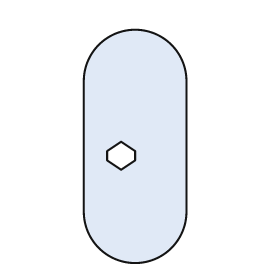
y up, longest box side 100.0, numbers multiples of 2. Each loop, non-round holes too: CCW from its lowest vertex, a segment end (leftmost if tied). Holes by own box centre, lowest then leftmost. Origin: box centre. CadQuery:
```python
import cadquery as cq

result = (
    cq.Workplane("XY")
    .moveTo(-22.0, -28.0)
    .threePointArc((0.0, -50.0), (22.0, -28.0))
    .lineTo(22.0, 28.0)
    .threePointArc((0.0, 50.0), (-22.0, 28.0))
    .close()
    .moveTo(-6.0, -10.0)
    .lineTo(0.0, -6.0)
    .lineTo(0.0, -2.0)
    .lineTo(-6.0, 2.0)
    .lineTo(-12.0, -2.0)
    .lineTo(-12.0, -6.0)
    .close()
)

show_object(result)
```